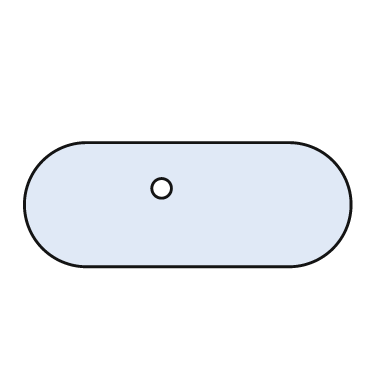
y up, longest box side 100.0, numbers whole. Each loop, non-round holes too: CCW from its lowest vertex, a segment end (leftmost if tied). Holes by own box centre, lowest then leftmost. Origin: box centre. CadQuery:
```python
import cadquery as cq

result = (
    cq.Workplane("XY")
    .moveTo(-31.0, -19.0)
    .lineTo(31.0, -19.0)
    .threePointArc((50.0, 0.0), (31.0, 19.0))
    .lineTo(-31.0, 19.0)
    .threePointArc((-50.0, 0.0), (-31.0, -19.0))
    .close()
    .moveTo(-8.0, 5.0)
    .circle(3.0)
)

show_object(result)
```